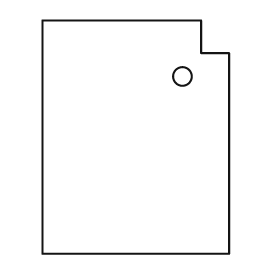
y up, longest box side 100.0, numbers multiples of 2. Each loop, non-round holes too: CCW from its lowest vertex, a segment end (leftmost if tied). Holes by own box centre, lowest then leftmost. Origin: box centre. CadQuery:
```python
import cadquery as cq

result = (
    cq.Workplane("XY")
    .moveTo(-40.0, -50.0)
    .lineTo(40.0, -50.0)
    .lineTo(40.0, 36.0)
    .lineTo(28.0, 36.0)
    .lineTo(28.0, 50.0)
    .lineTo(-40.0, 50.0)
    .close()
    .moveTo(20.0, 26.0)
    .circle(4.0)
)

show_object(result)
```